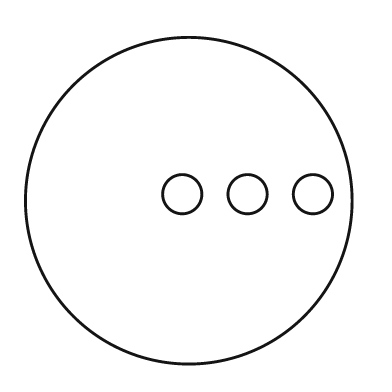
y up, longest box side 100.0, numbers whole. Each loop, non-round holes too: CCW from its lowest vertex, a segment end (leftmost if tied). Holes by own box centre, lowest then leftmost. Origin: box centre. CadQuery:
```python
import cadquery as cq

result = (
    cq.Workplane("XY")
    .moveTo(0.0, 0.0)
    .circle(50.0)
    .moveTo(-2.0, 2.0)
    .circle(6.0)
    .moveTo(18.0, 2.0)
    .circle(6.0)
    .moveTo(38.0, 2.0)
    .circle(6.0)
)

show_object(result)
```